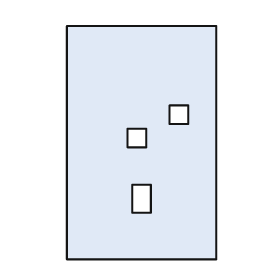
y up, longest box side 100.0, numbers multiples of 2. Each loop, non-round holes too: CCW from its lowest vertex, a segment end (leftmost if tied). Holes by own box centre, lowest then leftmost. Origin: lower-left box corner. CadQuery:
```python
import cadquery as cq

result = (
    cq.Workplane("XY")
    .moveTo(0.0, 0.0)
    .lineTo(64.0, 0.0)
    .lineTo(64.0, 100.0)
    .lineTo(0.0, 100.0)
    .close()
    .moveTo(28.0, 20.0)
    .lineTo(36.0, 20.0)
    .lineTo(36.0, 32.0)
    .lineTo(28.0, 32.0)
    .close()
    .moveTo(26.0, 48.0)
    .lineTo(34.0, 48.0)
    .lineTo(34.0, 56.0)
    .lineTo(26.0, 56.0)
    .close()
    .moveTo(44.0, 58.0)
    .lineTo(52.0, 58.0)
    .lineTo(52.0, 66.0)
    .lineTo(44.0, 66.0)
    .close()
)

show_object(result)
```